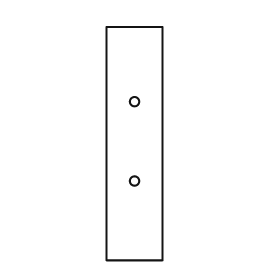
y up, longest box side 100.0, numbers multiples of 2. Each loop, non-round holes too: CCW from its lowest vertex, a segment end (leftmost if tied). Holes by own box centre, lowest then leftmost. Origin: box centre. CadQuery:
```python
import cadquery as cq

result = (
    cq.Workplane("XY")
    .moveTo(-12.0, -50.0)
    .lineTo(12.0, -50.0)
    .lineTo(12.0, 50.0)
    .lineTo(-12.0, 50.0)
    .close()
    .moveTo(0.0, -16.0)
    .circle(2.0)
    .moveTo(0.0, 18.0)
    .circle(2.0)
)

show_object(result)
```